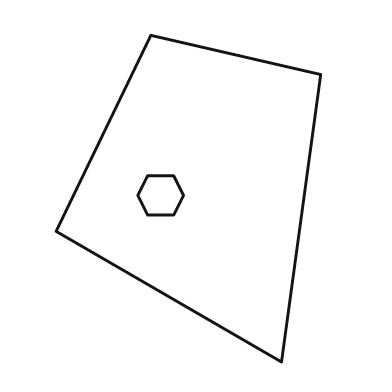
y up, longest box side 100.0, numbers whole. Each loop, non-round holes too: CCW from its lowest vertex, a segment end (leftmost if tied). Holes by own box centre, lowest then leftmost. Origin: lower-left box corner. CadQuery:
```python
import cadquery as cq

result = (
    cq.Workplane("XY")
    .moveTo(69.0, 0.0)
    .lineTo(81.0, 88.0)
    .lineTo(29.0, 100.0)
    .lineTo(0.0, 40.0)
    .close()
    .moveTo(28.0, 45.0)
    .lineTo(36.0, 45.0)
    .lineTo(39.0, 51.0)
    .lineTo(36.0, 57.0)
    .lineTo(28.0, 57.0)
    .lineTo(25.0, 51.0)
    .close()
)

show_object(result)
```